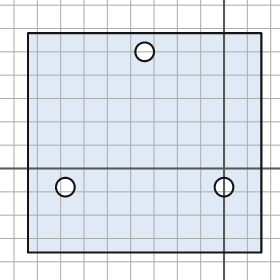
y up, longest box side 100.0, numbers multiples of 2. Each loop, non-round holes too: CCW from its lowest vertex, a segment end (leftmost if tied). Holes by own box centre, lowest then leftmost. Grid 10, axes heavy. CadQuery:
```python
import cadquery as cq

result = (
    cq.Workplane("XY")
    .moveTo(-84.0, -36.0)
    .lineTo(16.0, -36.0)
    .lineTo(16.0, 58.0)
    .lineTo(-84.0, 58.0)
    .close()
    .moveTo(-68.0, -8.0)
    .circle(4.0)
    .moveTo(0.0, -8.0)
    .circle(4.0)
    .moveTo(-34.0, 50.0)
    .circle(4.0)
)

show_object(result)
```